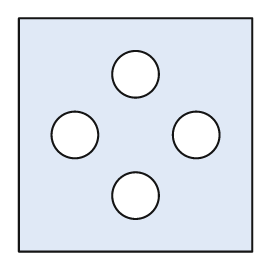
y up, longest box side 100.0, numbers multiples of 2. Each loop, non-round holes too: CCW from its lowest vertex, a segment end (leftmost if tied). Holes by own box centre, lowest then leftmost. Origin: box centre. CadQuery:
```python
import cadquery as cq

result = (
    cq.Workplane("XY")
    .moveTo(-50.0, -50.0)
    .lineTo(50.0, -50.0)
    .lineTo(50.0, 50.0)
    .lineTo(-50.0, 50.0)
    .close()
    .moveTo(0.0, -26.0)
    .circle(10.0)
    .moveTo(-26.0, 0.0)
    .circle(10.0)
    .moveTo(26.0, 0.0)
    .circle(10.0)
    .moveTo(0.0, 26.0)
    .circle(10.0)
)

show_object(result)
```